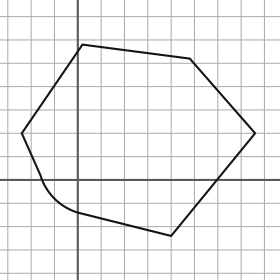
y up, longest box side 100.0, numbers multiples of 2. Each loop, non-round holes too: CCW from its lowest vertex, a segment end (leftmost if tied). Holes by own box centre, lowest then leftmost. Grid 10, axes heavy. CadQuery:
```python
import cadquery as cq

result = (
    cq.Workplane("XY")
    .moveTo(40.0, -24.0)
    .lineTo(76.0, 20.0)
    .lineTo(48.0, 52.0)
    .lineTo(2.0, 58.0)
    .lineTo(-24.0, 20.0)
    .lineTo(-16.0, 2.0)
    .threePointArc((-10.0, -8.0), (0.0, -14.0))
    .close()
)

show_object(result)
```